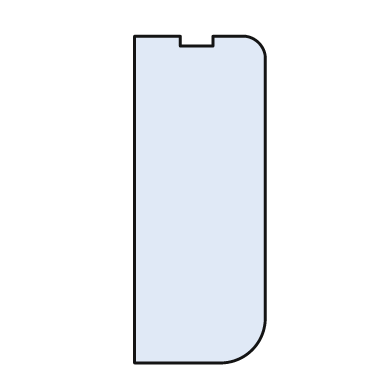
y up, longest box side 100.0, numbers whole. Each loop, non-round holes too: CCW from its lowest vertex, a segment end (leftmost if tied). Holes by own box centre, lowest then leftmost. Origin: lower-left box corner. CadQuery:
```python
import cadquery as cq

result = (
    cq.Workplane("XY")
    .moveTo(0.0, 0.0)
    .lineTo(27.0, 0.0)
    .threePointArc((36.0, 4.0), (40.0, 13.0))
    .lineTo(40.0, 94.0)
    .threePointArc((38.0, 98.0), (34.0, 100.0))
    .lineTo(24.0, 100.0)
    .lineTo(24.0, 97.0)
    .lineTo(14.0, 97.0)
    .lineTo(14.0, 100.0)
    .lineTo(0.0, 100.0)
    .close()
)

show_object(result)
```